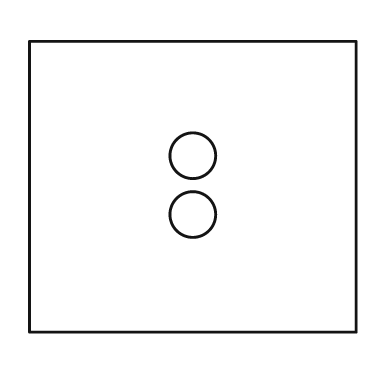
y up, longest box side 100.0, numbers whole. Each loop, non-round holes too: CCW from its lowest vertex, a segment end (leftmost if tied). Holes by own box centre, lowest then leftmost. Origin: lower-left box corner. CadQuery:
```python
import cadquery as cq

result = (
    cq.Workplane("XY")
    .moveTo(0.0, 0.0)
    .lineTo(100.0, 0.0)
    .lineTo(100.0, 89.0)
    .lineTo(0.0, 89.0)
    .close()
    .moveTo(50.0, 36.0)
    .circle(7.0)
    .moveTo(50.0, 54.0)
    .circle(7.0)
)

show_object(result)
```